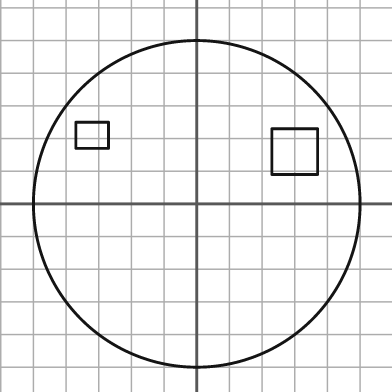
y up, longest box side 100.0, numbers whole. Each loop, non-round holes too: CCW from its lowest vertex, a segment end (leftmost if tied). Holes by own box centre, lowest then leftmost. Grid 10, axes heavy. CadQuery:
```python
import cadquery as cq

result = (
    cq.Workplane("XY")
    .moveTo(0.0, 0.0)
    .circle(50.0)
    .moveTo(23.0, 9.0)
    .lineTo(37.0, 9.0)
    .lineTo(37.0, 23.0)
    .lineTo(23.0, 23.0)
    .close()
    .moveTo(-37.0, 17.0)
    .lineTo(-27.0, 17.0)
    .lineTo(-27.0, 25.0)
    .lineTo(-37.0, 25.0)
    .close()
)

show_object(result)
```